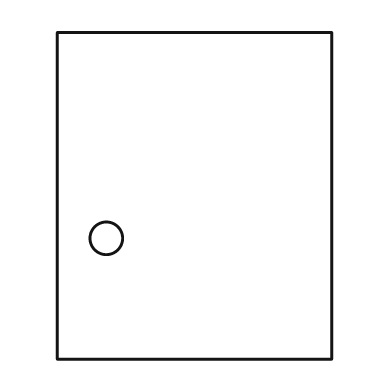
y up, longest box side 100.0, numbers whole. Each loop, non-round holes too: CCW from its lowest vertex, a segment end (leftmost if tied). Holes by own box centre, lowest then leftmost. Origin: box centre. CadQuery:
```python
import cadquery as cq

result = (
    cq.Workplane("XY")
    .moveTo(-42.0, -50.0)
    .lineTo(42.0, -50.0)
    .lineTo(42.0, 50.0)
    .lineTo(-42.0, 50.0)
    .close()
    .moveTo(-27.0, -13.0)
    .circle(5.0)
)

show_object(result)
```